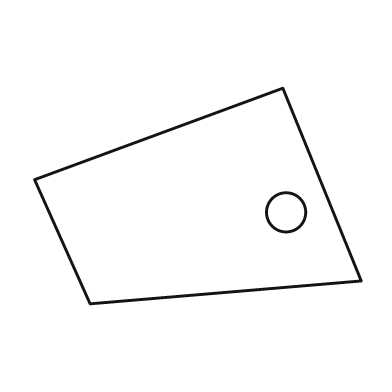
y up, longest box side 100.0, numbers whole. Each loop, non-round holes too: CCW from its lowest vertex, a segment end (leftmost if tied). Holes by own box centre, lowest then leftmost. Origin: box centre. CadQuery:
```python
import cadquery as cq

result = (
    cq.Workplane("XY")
    .moveTo(-33.0, -33.0)
    .lineTo(50.0, -26.0)
    .lineTo(26.0, 33.0)
    .lineTo(-50.0, 5.0)
    .close()
    .moveTo(27.0, -5.0)
    .circle(6.0)
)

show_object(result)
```